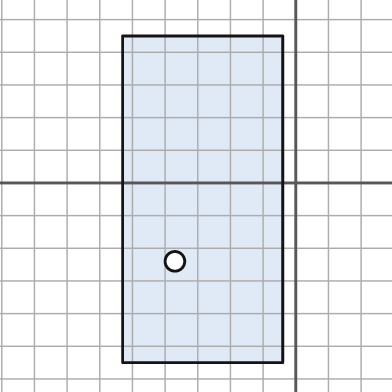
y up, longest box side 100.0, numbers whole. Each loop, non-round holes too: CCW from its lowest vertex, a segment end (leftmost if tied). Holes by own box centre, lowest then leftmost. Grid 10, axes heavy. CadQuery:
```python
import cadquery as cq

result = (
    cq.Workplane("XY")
    .moveTo(-53.0, -55.0)
    .lineTo(-4.0, -55.0)
    .lineTo(-4.0, 45.0)
    .lineTo(-53.0, 45.0)
    .close()
    .moveTo(-37.0, -24.0)
    .circle(3.0)
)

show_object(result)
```